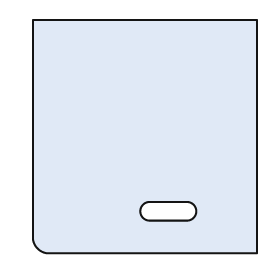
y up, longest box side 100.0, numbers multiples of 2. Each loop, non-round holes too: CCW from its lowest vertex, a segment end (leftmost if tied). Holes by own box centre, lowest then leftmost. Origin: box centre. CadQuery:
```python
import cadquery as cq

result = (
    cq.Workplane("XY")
    .moveTo(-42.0, -50.0)
    .lineTo(48.0, -50.0)
    .lineTo(48.0, 50.0)
    .lineTo(-48.0, 50.0)
    .lineTo(-48.0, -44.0)
    .threePointArc((-46.0, -48.0), (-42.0, -50.0))
    .close()
    .moveTo(2.0, -36.0)
    .lineTo(18.0, -36.0)
    .threePointArc((22.0, -32.0), (18.0, -28.0))
    .lineTo(2.0, -28.0)
    .threePointArc((-2.0, -32.0), (2.0, -36.0))
    .close()
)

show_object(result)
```